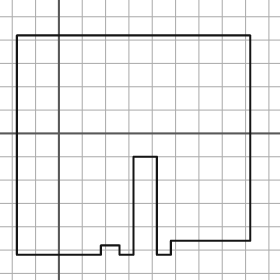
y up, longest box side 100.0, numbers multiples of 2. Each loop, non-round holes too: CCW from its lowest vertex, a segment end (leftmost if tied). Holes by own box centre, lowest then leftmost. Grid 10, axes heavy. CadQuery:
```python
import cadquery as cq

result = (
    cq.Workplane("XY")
    .moveTo(-18.0, -52.0)
    .lineTo(18.0, -52.0)
    .lineTo(18.0, -48.0)
    .lineTo(26.0, -48.0)
    .lineTo(26.0, -52.0)
    .lineTo(32.0, -52.0)
    .lineTo(32.0, -10.0)
    .lineTo(42.0, -10.0)
    .lineTo(42.0, -52.0)
    .lineTo(48.0, -52.0)
    .lineTo(48.0, -46.0)
    .lineTo(82.0, -46.0)
    .lineTo(82.0, 42.0)
    .lineTo(-18.0, 42.0)
    .close()
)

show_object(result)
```